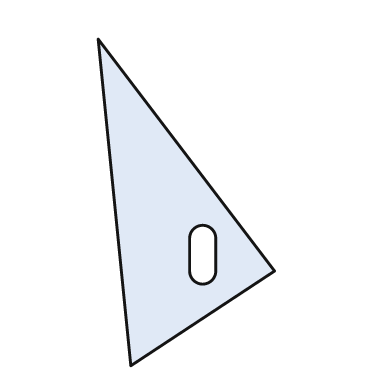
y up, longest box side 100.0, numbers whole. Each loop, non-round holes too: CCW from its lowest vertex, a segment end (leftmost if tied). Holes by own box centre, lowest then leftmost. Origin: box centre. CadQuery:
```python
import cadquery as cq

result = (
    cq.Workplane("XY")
    .moveTo(-17.0, -50.0)
    .lineTo(27.0, -21.0)
    .lineTo(-27.0, 50.0)
    .close()
    .moveTo(1.0, -21.0)
    .threePointArc((5.0, -25.0), (9.0, -21.0))
    .lineTo(9.0, -11.0)
    .threePointArc((5.0, -7.0), (1.0, -11.0))
    .close()
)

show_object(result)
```